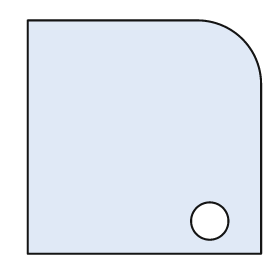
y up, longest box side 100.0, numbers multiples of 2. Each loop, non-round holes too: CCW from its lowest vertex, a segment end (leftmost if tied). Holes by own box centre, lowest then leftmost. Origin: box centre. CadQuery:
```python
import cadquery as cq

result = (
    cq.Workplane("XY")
    .moveTo(-50.0, -50.0)
    .lineTo(50.0, -50.0)
    .lineTo(50.0, 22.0)
    .threePointArc((42.0, 42.0), (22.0, 50.0))
    .lineTo(-50.0, 50.0)
    .close()
    .moveTo(28.0, -36.0)
    .circle(8.0)
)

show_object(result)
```